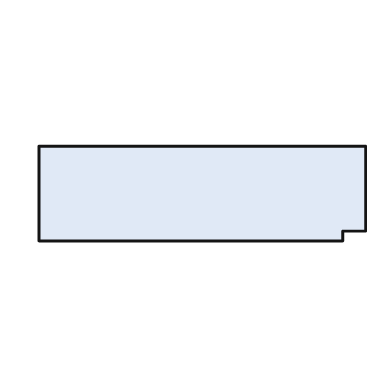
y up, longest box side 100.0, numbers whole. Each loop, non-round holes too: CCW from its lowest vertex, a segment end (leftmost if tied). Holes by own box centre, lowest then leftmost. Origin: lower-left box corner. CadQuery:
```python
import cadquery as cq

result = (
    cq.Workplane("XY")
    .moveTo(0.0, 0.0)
    .lineTo(93.0, 0.0)
    .lineTo(93.0, 3.0)
    .lineTo(100.0, 3.0)
    .lineTo(100.0, 29.0)
    .lineTo(0.0, 29.0)
    .close()
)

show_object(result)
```